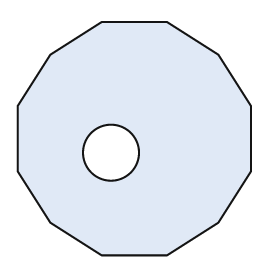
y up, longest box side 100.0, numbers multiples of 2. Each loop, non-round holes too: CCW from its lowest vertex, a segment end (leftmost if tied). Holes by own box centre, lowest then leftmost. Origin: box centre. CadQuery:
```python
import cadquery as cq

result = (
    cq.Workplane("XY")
    .moveTo(-14.0, -50.0)
    .lineTo(14.0, -50.0)
    .lineTo(36.0, -36.0)
    .lineTo(50.0, -14.0)
    .lineTo(50.0, 14.0)
    .lineTo(36.0, 36.0)
    .lineTo(14.0, 50.0)
    .lineTo(-14.0, 50.0)
    .lineTo(-36.0, 36.0)
    .lineTo(-50.0, 14.0)
    .lineTo(-50.0, -14.0)
    .lineTo(-36.0, -36.0)
    .close()
    .moveTo(-10.0, -6.0)
    .circle(12.0)
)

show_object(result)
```